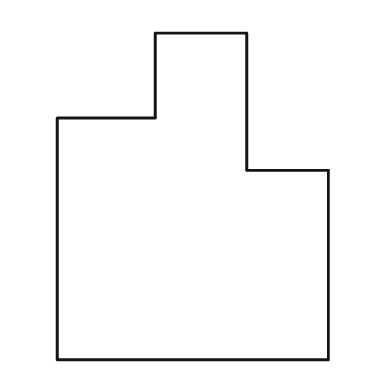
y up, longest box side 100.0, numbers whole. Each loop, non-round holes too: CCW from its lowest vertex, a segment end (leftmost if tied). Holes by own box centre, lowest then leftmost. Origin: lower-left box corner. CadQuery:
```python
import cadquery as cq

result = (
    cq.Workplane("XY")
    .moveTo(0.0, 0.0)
    .lineTo(83.0, 0.0)
    .lineTo(83.0, 58.0)
    .lineTo(58.0, 58.0)
    .lineTo(58.0, 100.0)
    .lineTo(30.0, 100.0)
    .lineTo(30.0, 74.0)
    .lineTo(0.0, 74.0)
    .close()
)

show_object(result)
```